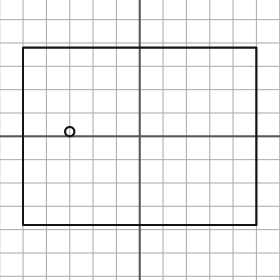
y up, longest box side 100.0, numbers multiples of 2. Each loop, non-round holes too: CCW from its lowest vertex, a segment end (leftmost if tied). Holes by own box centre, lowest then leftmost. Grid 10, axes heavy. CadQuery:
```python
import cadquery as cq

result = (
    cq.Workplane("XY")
    .moveTo(-50.0, -38.0)
    .lineTo(50.0, -38.0)
    .lineTo(50.0, 38.0)
    .lineTo(-50.0, 38.0)
    .close()
    .moveTo(-30.0, 2.0)
    .circle(2.0)
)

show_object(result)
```